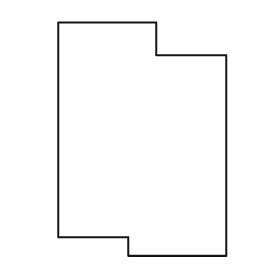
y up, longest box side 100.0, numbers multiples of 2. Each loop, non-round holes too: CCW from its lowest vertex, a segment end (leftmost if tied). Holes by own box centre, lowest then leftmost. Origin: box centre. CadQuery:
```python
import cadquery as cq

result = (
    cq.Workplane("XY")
    .moveTo(-6.0, -50.0)
    .lineTo(36.0, -50.0)
    .lineTo(36.0, 36.0)
    .lineTo(6.0, 36.0)
    .lineTo(6.0, 50.0)
    .lineTo(-36.0, 50.0)
    .lineTo(-36.0, -42.0)
    .lineTo(-6.0, -42.0)
    .close()
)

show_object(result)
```